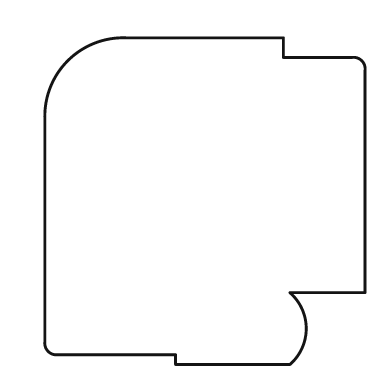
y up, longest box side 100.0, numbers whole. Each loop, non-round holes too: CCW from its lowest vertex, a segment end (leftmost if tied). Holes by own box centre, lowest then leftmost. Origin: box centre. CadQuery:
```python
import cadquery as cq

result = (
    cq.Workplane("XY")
    .moveTo(-9.0, -50.0)
    .lineTo(26.0, -50.0)
    .threePointArc((31.0, -39.0), (26.0, -28.0))
    .lineTo(49.0, -28.0)
    .lineTo(49.0, 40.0)
    .threePointArc((48.0, 43.0), (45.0, 44.0))
    .lineTo(24.0, 44.0)
    .lineTo(24.0, 50.0)
    .lineTo(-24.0, 50.0)
    .threePointArc((-42.0, 43.0), (-49.0, 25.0))
    .lineTo(-49.0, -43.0)
    .threePointArc((-48.0, -46.0), (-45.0, -47.0))
    .lineTo(-9.0, -47.0)
    .close()
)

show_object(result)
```